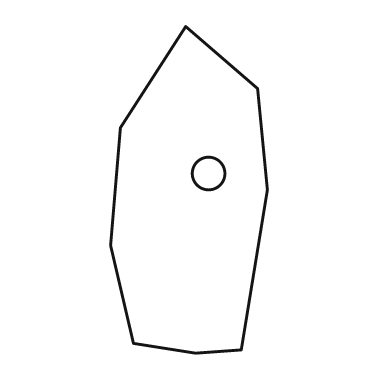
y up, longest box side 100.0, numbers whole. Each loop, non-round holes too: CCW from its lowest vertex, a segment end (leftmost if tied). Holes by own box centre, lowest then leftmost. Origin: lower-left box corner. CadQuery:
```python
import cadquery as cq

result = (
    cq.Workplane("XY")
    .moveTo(26.0, 0.0)
    .lineTo(40.0, 1.0)
    .lineTo(48.0, 50.0)
    .lineTo(45.0, 81.0)
    .lineTo(23.0, 100.0)
    .lineTo(3.0, 69.0)
    .lineTo(0.0, 33.0)
    .lineTo(7.0, 3.0)
    .close()
    .moveTo(30.0, 55.0)
    .circle(5.0)
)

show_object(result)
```